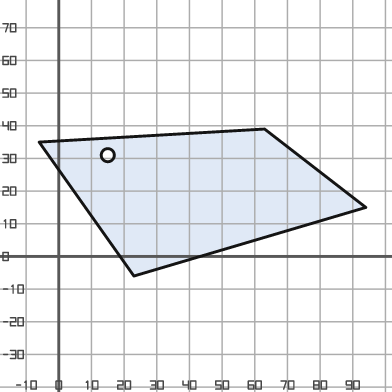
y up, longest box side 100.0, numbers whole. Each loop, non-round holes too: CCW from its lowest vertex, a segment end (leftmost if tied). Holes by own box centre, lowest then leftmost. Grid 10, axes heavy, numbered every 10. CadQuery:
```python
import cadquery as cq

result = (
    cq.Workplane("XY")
    .moveTo(23.0, -6.0)
    .lineTo(94.0, 15.0)
    .lineTo(63.0, 39.0)
    .lineTo(-6.0, 35.0)
    .close()
    .moveTo(15.0, 31.0)
    .circle(2.0)
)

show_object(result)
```